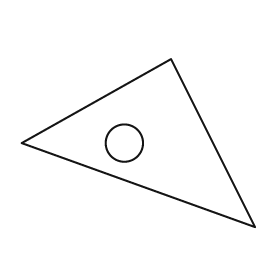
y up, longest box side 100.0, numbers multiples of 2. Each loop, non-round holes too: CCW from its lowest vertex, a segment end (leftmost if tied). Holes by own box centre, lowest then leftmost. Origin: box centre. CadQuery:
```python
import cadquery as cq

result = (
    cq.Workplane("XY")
    .moveTo(50.0, -36.0)
    .lineTo(14.0, 36.0)
    .lineTo(-50.0, 0.0)
    .close()
    .moveTo(-6.0, 0.0)
    .circle(8.0)
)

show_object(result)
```